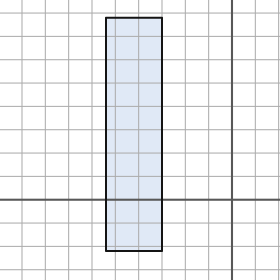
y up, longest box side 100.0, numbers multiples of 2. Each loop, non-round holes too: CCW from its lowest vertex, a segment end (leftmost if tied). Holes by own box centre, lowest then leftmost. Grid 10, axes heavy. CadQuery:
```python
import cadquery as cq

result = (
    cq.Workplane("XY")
    .moveTo(-54.0, -22.0)
    .lineTo(-30.0, -22.0)
    .lineTo(-30.0, 78.0)
    .lineTo(-54.0, 78.0)
    .close()
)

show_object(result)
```